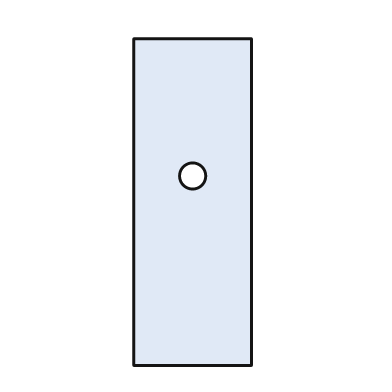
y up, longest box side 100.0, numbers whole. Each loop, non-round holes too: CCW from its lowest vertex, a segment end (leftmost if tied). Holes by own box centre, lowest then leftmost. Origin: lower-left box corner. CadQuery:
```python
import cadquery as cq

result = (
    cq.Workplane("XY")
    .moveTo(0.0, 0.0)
    .lineTo(36.0, 0.0)
    .lineTo(36.0, 100.0)
    .lineTo(0.0, 100.0)
    .close()
    .moveTo(18.0, 58.0)
    .circle(4.0)
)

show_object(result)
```